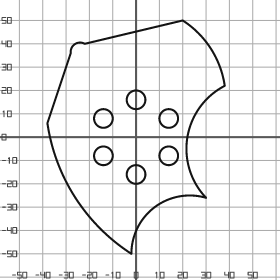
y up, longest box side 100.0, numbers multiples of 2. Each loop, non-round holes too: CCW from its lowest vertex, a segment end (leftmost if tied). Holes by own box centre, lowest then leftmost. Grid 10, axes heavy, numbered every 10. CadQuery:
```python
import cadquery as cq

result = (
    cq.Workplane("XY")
    .moveTo(-2.0, -50.0)
    .threePointArc((8.0, -30.0), (30.0, -26.0))
    .threePointArc((22.0, 0.0), (38.0, 22.0))
    .threePointArc((32.0, 38.0), (20.0, 50.0))
    .lineTo(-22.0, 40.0)
    .threePointArc((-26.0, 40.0), (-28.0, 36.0))
    .lineTo(-38.0, 6.0)
    .threePointArc((-26.0, -26.0), (-2.0, -50.0))
    .close()
    .moveTo(0.0, -16.0)
    .circle(4.0)
    .moveTo(-14.0, -8.0)
    .circle(4.0)
    .moveTo(14.0, -8.0)
    .circle(4.0)
    .moveTo(-14.0, 8.0)
    .circle(4.0)
    .moveTo(14.0, 8.0)
    .circle(4.0)
    .moveTo(0.0, 16.0)
    .circle(4.0)
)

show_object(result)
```